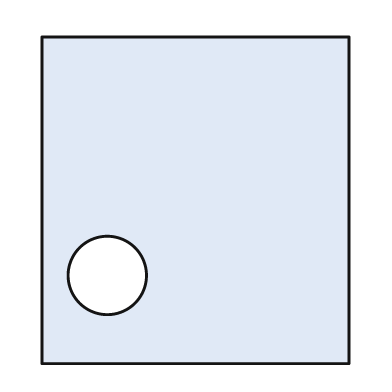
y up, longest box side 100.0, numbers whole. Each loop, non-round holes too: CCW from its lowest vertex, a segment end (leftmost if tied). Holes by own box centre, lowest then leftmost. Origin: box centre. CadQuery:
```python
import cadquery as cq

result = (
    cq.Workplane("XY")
    .moveTo(-47.0, -50.0)
    .lineTo(47.0, -50.0)
    .lineTo(47.0, 50.0)
    .lineTo(-47.0, 50.0)
    .close()
    .moveTo(-27.0, -23.0)
    .circle(12.0)
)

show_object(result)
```